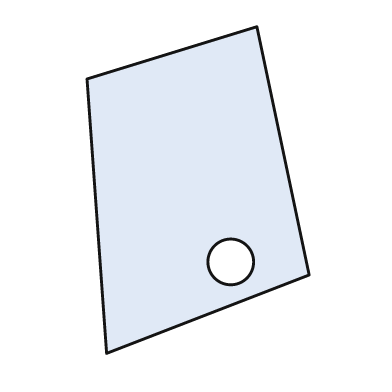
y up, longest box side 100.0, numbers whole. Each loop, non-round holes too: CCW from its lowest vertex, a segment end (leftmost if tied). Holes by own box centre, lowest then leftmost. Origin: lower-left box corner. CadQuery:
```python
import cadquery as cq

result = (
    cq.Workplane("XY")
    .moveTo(6.0, 0.0)
    .lineTo(68.0, 24.0)
    .lineTo(52.0, 100.0)
    .lineTo(0.0, 84.0)
    .close()
    .moveTo(44.0, 28.0)
    .circle(7.0)
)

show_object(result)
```